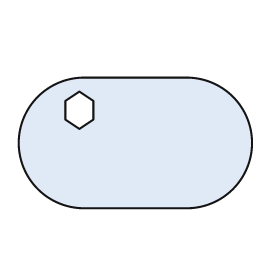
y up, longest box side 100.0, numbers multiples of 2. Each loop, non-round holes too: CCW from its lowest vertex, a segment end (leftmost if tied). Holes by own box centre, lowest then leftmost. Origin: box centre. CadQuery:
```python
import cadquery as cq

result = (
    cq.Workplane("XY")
    .moveTo(-22.0, -28.0)
    .lineTo(22.0, -28.0)
    .threePointArc((50.0, 0.0), (22.0, 28.0))
    .lineTo(-22.0, 28.0)
    .threePointArc((-50.0, 0.0), (-22.0, -28.0))
    .close()
    .moveTo(-24.0, 6.0)
    .lineTo(-18.0, 10.0)
    .lineTo(-18.0, 18.0)
    .lineTo(-24.0, 22.0)
    .lineTo(-30.0, 18.0)
    .lineTo(-30.0, 10.0)
    .close()
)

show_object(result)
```